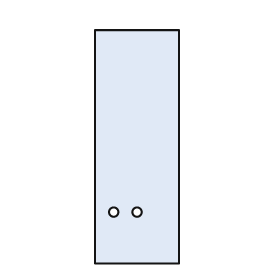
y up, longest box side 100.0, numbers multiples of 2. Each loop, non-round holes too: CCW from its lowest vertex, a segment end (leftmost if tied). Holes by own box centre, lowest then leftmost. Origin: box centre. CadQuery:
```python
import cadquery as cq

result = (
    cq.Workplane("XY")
    .moveTo(-18.0, -50.0)
    .lineTo(18.0, -50.0)
    .lineTo(18.0, 50.0)
    .lineTo(-18.0, 50.0)
    .close()
    .moveTo(-10.0, -28.0)
    .circle(2.0)
    .moveTo(0.0, -28.0)
    .circle(2.0)
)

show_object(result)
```